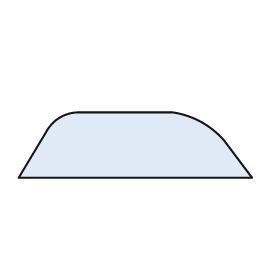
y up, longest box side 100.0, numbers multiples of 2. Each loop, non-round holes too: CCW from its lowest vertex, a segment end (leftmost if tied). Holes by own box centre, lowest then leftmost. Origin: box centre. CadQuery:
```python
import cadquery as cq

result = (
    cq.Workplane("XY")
    .moveTo(-50.0, -14.0)
    .lineTo(50.0, -14.0)
    .lineTo(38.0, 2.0)
    .threePointArc((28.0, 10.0), (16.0, 14.0))
    .lineTo(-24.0, 14.0)
    .threePointArc((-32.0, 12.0), (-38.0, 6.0))
    .close()
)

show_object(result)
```